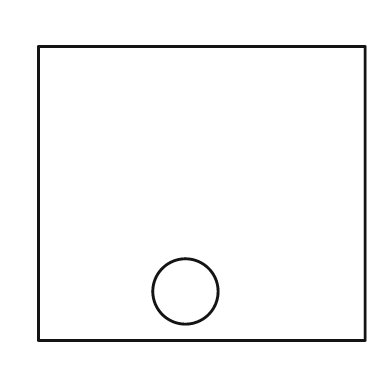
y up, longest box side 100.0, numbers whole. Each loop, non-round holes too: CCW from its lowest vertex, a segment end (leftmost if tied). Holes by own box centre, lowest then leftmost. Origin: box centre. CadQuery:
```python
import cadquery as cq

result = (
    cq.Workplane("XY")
    .moveTo(-50.0, -45.0)
    .lineTo(50.0, -45.0)
    .lineTo(50.0, 45.0)
    .lineTo(-50.0, 45.0)
    .close()
    .moveTo(-5.0, -30.0)
    .circle(10.0)
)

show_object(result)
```